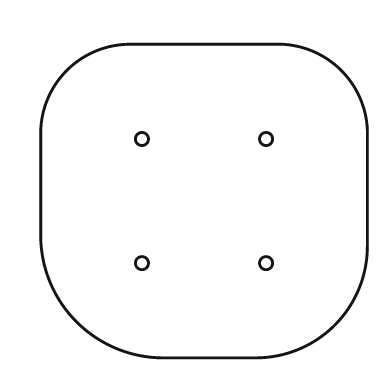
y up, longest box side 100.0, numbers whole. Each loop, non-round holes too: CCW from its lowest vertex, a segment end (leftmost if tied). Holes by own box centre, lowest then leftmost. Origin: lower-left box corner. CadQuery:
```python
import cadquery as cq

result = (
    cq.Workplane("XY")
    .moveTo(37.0, 0.0)
    .lineTo(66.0, 0.0)
    .threePointArc((90.0, 10.0), (100.0, 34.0))
    .lineTo(100.0, 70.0)
    .threePointArc((92.0, 88.0), (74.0, 96.0))
    .lineTo(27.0, 96.0)
    .threePointArc((8.0, 88.0), (0.0, 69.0))
    .lineTo(0.0, 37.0)
    .threePointArc((11.0, 11.0), (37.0, 0.0))
    .close()
    .moveTo(31.0, 29.0)
    .circle(2.0)
    .moveTo(69.0, 29.0)
    .circle(2.0)
    .moveTo(31.0, 67.0)
    .circle(2.0)
    .moveTo(69.0, 67.0)
    .circle(2.0)
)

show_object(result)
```